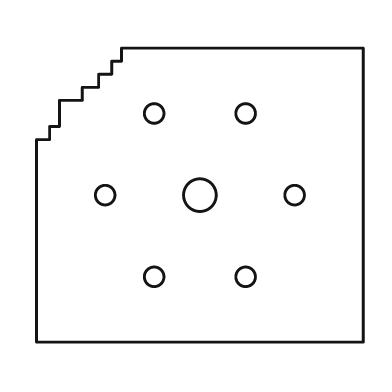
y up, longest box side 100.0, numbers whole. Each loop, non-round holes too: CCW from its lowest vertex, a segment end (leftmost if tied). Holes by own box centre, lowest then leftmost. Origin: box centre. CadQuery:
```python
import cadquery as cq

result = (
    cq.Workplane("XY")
    .moveTo(-50.0, -45.0)
    .lineTo(50.0, -45.0)
    .lineTo(50.0, 45.0)
    .lineTo(-24.0, 45.0)
    .lineTo(-24.0, 41.0)
    .lineTo(-27.0, 41.0)
    .lineTo(-27.0, 37.0)
    .lineTo(-31.0, 37.0)
    .lineTo(-31.0, 33.0)
    .lineTo(-36.0, 33.0)
    .lineTo(-36.0, 29.0)
    .lineTo(-43.0, 29.0)
    .lineTo(-43.0, 21.0)
    .lineTo(-46.0, 21.0)
    .lineTo(-46.0, 17.0)
    .lineTo(-50.0, 17.0)
    .close()
    .moveTo(-14.0, -25.0)
    .circle(3.0)
    .moveTo(14.0, -25.0)
    .circle(3.0)
    .moveTo(-29.0, 0.0)
    .circle(3.0)
    .moveTo(0.0, 0.0)
    .circle(5.0)
    .moveTo(29.0, 0.0)
    .circle(3.0)
    .moveTo(-14.0, 25.0)
    .circle(3.0)
    .moveTo(14.0, 25.0)
    .circle(3.0)
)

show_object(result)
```